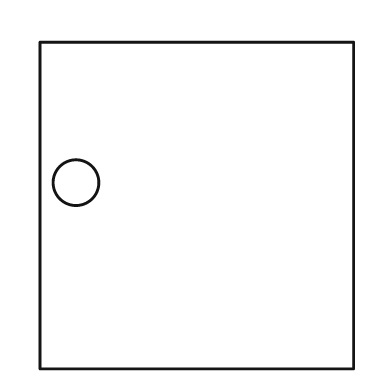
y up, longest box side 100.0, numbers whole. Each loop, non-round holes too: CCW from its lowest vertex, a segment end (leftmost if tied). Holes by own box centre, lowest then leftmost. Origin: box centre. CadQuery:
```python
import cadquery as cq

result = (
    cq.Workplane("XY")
    .moveTo(-48.0, -50.0)
    .lineTo(48.0, -50.0)
    .lineTo(48.0, 50.0)
    .lineTo(-48.0, 50.0)
    .close()
    .moveTo(-37.0, 7.0)
    .circle(7.0)
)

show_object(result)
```